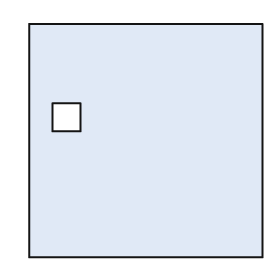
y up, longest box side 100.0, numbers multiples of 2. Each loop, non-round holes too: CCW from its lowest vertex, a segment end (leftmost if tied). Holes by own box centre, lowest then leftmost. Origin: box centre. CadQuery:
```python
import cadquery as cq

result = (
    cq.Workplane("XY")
    .moveTo(-50.0, -50.0)
    .lineTo(50.0, -50.0)
    .lineTo(50.0, 50.0)
    .lineTo(-50.0, 50.0)
    .close()
    .moveTo(-40.0, 4.0)
    .lineTo(-28.0, 4.0)
    .lineTo(-28.0, 16.0)
    .lineTo(-40.0, 16.0)
    .close()
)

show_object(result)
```